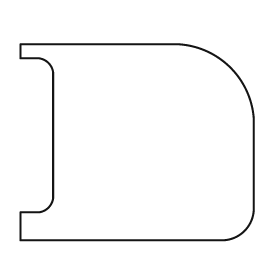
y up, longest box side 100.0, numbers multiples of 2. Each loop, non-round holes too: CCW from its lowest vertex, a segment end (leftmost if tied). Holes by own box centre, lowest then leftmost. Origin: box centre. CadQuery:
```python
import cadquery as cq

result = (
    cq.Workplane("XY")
    .moveTo(-50.0, -42.0)
    .lineTo(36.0, -42.0)
    .threePointArc((46.0, -38.0), (50.0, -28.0))
    .lineTo(50.0, 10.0)
    .threePointArc((40.0, 32.0), (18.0, 42.0))
    .lineTo(-50.0, 42.0)
    .lineTo(-50.0, 36.0)
    .lineTo(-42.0, 36.0)
    .threePointArc((-38.0, 34.0), (-36.0, 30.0))
    .lineTo(-36.0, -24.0)
    .threePointArc((-38.0, -28.0), (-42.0, -30.0))
    .lineTo(-50.0, -30.0)
    .close()
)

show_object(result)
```